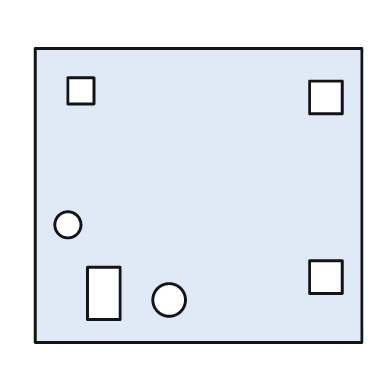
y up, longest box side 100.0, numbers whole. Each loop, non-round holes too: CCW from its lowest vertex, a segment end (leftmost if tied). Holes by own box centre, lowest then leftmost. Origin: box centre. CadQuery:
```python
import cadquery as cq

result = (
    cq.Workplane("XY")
    .moveTo(-50.0, -45.0)
    .lineTo(50.0, -45.0)
    .lineTo(50.0, 45.0)
    .lineTo(-50.0, 45.0)
    .close()
    .moveTo(-9.0, -32.0)
    .circle(5.0)
    .moveTo(-34.0, -38.0)
    .lineTo(-24.0, -38.0)
    .lineTo(-24.0, -22.0)
    .lineTo(-34.0, -22.0)
    .close()
    .moveTo(34.0, -30.0)
    .lineTo(44.0, -30.0)
    .lineTo(44.0, -20.0)
    .lineTo(34.0, -20.0)
    .close()
    .moveTo(-40.0, -9.0)
    .circle(4.0)
    .moveTo(34.0, 25.0)
    .lineTo(44.0, 25.0)
    .lineTo(44.0, 35.0)
    .lineTo(34.0, 35.0)
    .close()
    .moveTo(-40.0, 28.0)
    .lineTo(-32.0, 28.0)
    .lineTo(-32.0, 36.0)
    .lineTo(-40.0, 36.0)
    .close()
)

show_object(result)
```